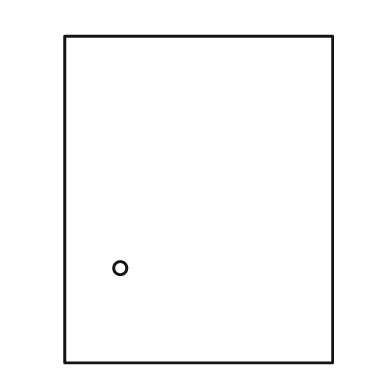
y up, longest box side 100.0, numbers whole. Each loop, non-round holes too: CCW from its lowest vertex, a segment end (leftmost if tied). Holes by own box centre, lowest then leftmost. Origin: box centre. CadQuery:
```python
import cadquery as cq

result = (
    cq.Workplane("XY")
    .moveTo(-41.0, -50.0)
    .lineTo(41.0, -50.0)
    .lineTo(41.0, 50.0)
    .lineTo(-41.0, 50.0)
    .close()
    .moveTo(-24.0, -21.0)
    .circle(2.0)
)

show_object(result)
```